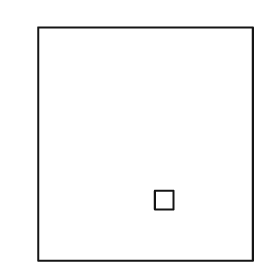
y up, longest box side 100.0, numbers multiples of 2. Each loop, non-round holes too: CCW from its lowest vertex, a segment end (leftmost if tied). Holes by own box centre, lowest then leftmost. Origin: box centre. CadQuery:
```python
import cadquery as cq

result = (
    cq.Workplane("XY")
    .moveTo(-46.0, -50.0)
    .lineTo(46.0, -50.0)
    .lineTo(46.0, 50.0)
    .lineTo(-46.0, 50.0)
    .close()
    .moveTo(4.0, -28.0)
    .lineTo(12.0, -28.0)
    .lineTo(12.0, -20.0)
    .lineTo(4.0, -20.0)
    .close()
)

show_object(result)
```